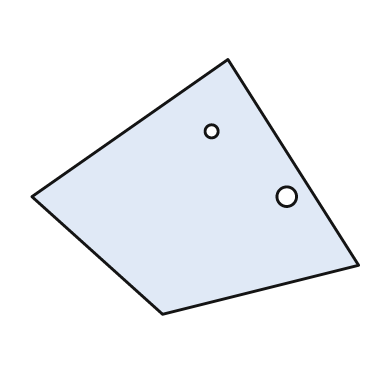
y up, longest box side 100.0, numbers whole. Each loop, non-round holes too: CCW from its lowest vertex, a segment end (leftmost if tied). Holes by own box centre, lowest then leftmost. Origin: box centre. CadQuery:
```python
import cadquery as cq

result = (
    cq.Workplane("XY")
    .moveTo(-10.0, -39.0)
    .lineTo(50.0, -24.0)
    .lineTo(10.0, 39.0)
    .lineTo(-50.0, -3.0)
    .close()
    .moveTo(28.0, -3.0)
    .circle(3.0)
    .moveTo(5.0, 17.0)
    .circle(2.0)
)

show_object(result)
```